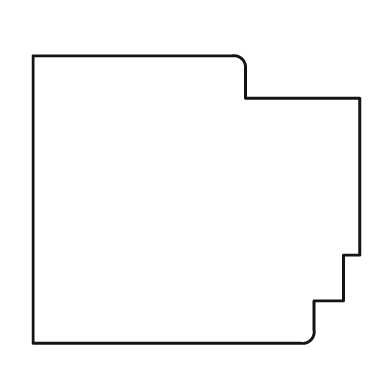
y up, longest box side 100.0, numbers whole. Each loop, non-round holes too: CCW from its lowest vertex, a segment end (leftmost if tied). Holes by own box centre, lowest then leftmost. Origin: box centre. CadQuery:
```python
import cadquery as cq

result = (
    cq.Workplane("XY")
    .moveTo(-50.0, -44.0)
    .lineTo(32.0, -44.0)
    .threePointArc((35.0, -43.0), (36.0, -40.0))
    .lineTo(36.0, -31.0)
    .lineTo(45.0, -31.0)
    .lineTo(45.0, -17.0)
    .lineTo(50.0, -17.0)
    .lineTo(50.0, 31.0)
    .lineTo(15.0, 31.0)
    .lineTo(15.0, 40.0)
    .threePointArc((14.0, 43.0), (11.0, 44.0))
    .lineTo(-50.0, 44.0)
    .close()
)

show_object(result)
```